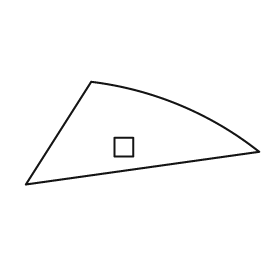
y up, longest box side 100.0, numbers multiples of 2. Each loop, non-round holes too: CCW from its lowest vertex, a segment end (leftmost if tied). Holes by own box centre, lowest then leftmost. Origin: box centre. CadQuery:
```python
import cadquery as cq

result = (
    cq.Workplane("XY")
    .moveTo(-50.0, -22.0)
    .lineTo(50.0, -8.0)
    .threePointArc((16.0, 12.0), (-22.0, 22.0))
    .close()
    .moveTo(-12.0, -10.0)
    .lineTo(-4.0, -10.0)
    .lineTo(-4.0, -2.0)
    .lineTo(-12.0, -2.0)
    .close()
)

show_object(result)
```